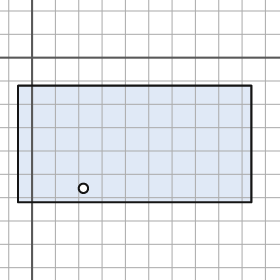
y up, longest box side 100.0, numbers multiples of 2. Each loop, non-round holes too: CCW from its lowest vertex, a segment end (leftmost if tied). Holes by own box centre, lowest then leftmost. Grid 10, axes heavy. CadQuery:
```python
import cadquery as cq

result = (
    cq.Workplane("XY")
    .moveTo(-6.0, -62.0)
    .lineTo(94.0, -62.0)
    .lineTo(94.0, -12.0)
    .lineTo(-6.0, -12.0)
    .close()
    .moveTo(22.0, -56.0)
    .circle(2.0)
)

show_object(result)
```